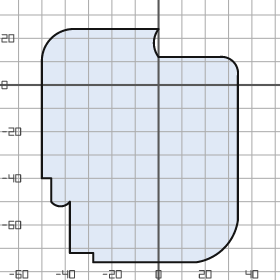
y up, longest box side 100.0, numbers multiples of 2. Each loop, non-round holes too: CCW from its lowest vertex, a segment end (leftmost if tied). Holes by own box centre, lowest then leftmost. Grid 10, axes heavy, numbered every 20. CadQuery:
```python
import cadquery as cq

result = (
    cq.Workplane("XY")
    .moveTo(-28.0, -76.0)
    .lineTo(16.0, -76.0)
    .threePointArc((28.0, -70.0), (34.0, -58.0))
    .lineTo(34.0, 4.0)
    .threePointArc((32.0, 10.0), (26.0, 12.0))
    .lineTo(0.0, 12.0)
    .threePointArc((-2.0, 18.0), (0.0, 24.0))
    .lineTo(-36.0, 24.0)
    .threePointArc((-46.0, 20.0), (-50.0, 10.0))
    .lineTo(-50.0, -40.0)
    .lineTo(-46.0, -40.0)
    .lineTo(-46.0, -50.0)
    .threePointArc((-42.0, -52.0), (-38.0, -50.0))
    .lineTo(-38.0, -72.0)
    .lineTo(-28.0, -72.0)
    .close()
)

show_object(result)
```